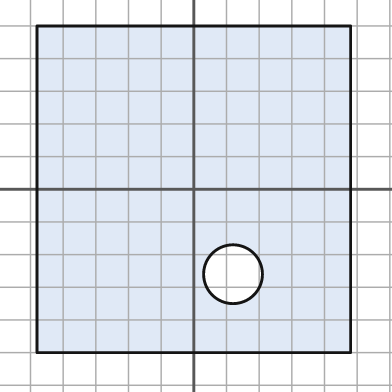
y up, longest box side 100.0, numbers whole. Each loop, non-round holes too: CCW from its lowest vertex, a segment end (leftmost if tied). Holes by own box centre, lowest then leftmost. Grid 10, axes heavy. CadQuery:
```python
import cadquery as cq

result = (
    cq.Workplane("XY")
    .moveTo(-48.0, -50.0)
    .lineTo(48.0, -50.0)
    .lineTo(48.0, 50.0)
    .lineTo(-48.0, 50.0)
    .close()
    .moveTo(12.0, -26.0)
    .circle(9.0)
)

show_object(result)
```